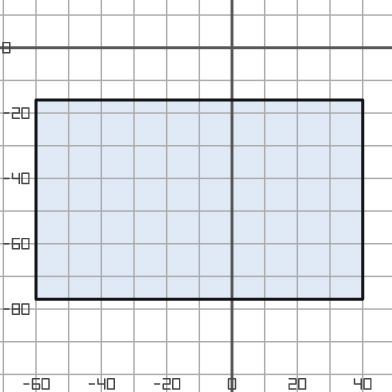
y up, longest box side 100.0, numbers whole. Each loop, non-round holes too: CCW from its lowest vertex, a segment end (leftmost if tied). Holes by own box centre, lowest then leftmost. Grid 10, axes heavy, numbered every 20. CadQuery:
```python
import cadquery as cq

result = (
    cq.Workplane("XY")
    .moveTo(-60.0, -77.0)
    .lineTo(40.0, -77.0)
    .lineTo(40.0, -16.0)
    .lineTo(-60.0, -16.0)
    .close()
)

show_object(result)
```